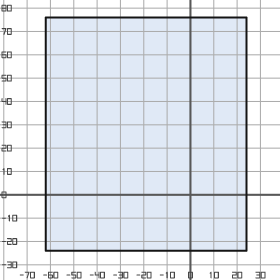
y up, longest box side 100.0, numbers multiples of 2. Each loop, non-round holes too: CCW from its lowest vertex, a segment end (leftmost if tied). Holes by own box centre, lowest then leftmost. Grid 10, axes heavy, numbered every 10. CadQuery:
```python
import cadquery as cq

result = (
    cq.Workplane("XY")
    .moveTo(-62.0, -24.0)
    .lineTo(24.0, -24.0)
    .lineTo(24.0, 76.0)
    .lineTo(-62.0, 76.0)
    .close()
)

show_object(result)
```